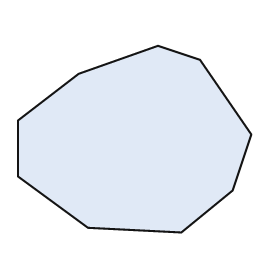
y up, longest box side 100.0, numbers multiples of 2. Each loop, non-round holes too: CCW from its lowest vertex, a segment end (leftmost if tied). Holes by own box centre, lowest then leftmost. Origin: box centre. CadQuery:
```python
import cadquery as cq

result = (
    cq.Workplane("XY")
    .moveTo(20.0, -40.0)
    .lineTo(42.0, -22.0)
    .lineTo(50.0, 2.0)
    .lineTo(28.0, 34.0)
    .lineTo(10.0, 40.0)
    .lineTo(-24.0, 28.0)
    .lineTo(-50.0, 8.0)
    .lineTo(-50.0, -16.0)
    .lineTo(-20.0, -38.0)
    .close()
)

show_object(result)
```